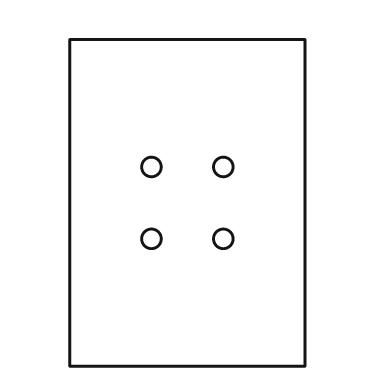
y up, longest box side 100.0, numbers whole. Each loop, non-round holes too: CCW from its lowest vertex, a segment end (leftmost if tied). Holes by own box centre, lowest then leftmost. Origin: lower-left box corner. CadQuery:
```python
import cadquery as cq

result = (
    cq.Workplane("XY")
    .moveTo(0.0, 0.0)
    .lineTo(72.0, 0.0)
    .lineTo(72.0, 100.0)
    .lineTo(0.0, 100.0)
    .close()
    .moveTo(25.0, 39.0)
    .circle(3.0)
    .moveTo(47.0, 39.0)
    .circle(3.0)
    .moveTo(25.0, 61.0)
    .circle(3.0)
    .moveTo(47.0, 61.0)
    .circle(3.0)
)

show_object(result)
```